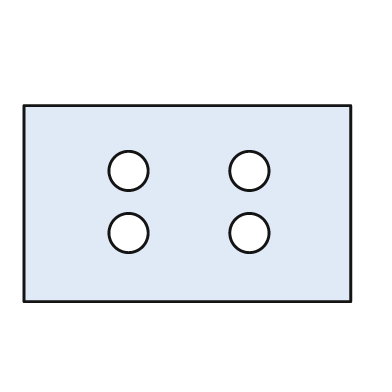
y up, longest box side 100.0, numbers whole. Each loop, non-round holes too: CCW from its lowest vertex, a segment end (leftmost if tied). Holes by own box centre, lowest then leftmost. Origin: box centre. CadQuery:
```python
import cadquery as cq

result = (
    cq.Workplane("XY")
    .moveTo(-50.0, -30.0)
    .lineTo(50.0, -30.0)
    .lineTo(50.0, 30.0)
    .lineTo(-50.0, 30.0)
    .close()
    .moveTo(-18.0, -9.0)
    .circle(6.0)
    .moveTo(19.0, -9.0)
    .circle(6.0)
    .moveTo(-18.0, 10.0)
    .circle(6.0)
    .moveTo(19.0, 10.0)
    .circle(6.0)
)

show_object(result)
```